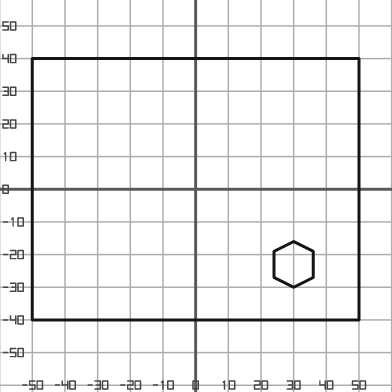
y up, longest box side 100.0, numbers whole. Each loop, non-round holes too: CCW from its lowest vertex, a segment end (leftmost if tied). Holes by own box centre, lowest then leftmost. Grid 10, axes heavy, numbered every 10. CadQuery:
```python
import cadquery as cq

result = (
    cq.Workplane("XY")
    .moveTo(-50.0, -40.0)
    .lineTo(50.0, -40.0)
    .lineTo(50.0, 40.0)
    .lineTo(-50.0, 40.0)
    .close()
    .moveTo(30.0, -30.0)
    .lineTo(36.0, -27.0)
    .lineTo(36.0, -19.0)
    .lineTo(30.0, -16.0)
    .lineTo(24.0, -19.0)
    .lineTo(24.0, -27.0)
    .close()
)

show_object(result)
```